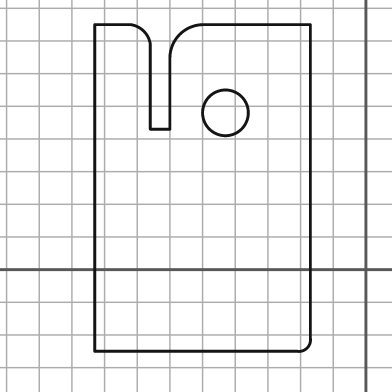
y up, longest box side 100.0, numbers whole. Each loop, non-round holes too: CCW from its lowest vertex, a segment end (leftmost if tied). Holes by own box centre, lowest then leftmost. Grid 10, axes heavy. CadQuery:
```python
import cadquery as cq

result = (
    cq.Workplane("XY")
    .moveTo(-83.0, -25.0)
    .lineTo(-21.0, -25.0)
    .threePointArc((-18.0, -24.0), (-17.0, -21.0))
    .lineTo(-17.0, 75.0)
    .lineTo(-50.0, 75.0)
    .threePointArc((-57.0, 72.0), (-60.0, 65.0))
    .lineTo(-60.0, 43.0)
    .lineTo(-66.0, 43.0)
    .lineTo(-66.0, 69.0)
    .threePointArc((-68.0, 73.0), (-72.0, 75.0))
    .lineTo(-83.0, 75.0)
    .close()
    .moveTo(-43.0, 48.0)
    .circle(7.0)
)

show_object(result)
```